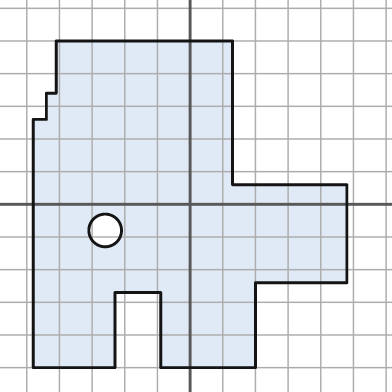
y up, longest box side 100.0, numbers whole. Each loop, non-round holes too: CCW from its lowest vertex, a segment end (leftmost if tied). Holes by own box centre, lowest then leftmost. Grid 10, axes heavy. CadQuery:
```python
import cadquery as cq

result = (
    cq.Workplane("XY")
    .moveTo(-48.0, -50.0)
    .lineTo(-23.0, -50.0)
    .lineTo(-23.0, -27.0)
    .lineTo(-9.0, -27.0)
    .lineTo(-9.0, -50.0)
    .lineTo(20.0, -50.0)
    .lineTo(20.0, -24.0)
    .lineTo(48.0, -24.0)
    .lineTo(48.0, 6.0)
    .lineTo(13.0, 6.0)
    .lineTo(13.0, 50.0)
    .lineTo(-41.0, 50.0)
    .lineTo(-41.0, 34.0)
    .lineTo(-44.0, 34.0)
    .lineTo(-44.0, 26.0)
    .lineTo(-48.0, 26.0)
    .close()
    .moveTo(-26.0, -8.0)
    .circle(5.0)
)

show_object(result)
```